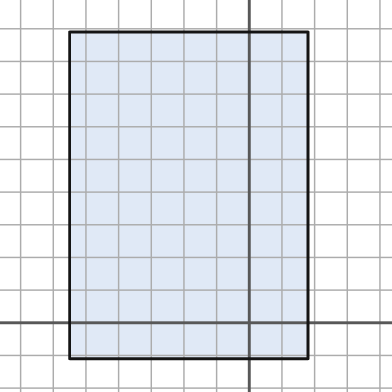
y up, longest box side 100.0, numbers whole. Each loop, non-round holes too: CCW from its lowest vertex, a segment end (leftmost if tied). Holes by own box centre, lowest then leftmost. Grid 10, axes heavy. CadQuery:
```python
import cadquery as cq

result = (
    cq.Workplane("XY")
    .moveTo(-55.0, -11.0)
    .lineTo(18.0, -11.0)
    .lineTo(18.0, 89.0)
    .lineTo(-55.0, 89.0)
    .close()
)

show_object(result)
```